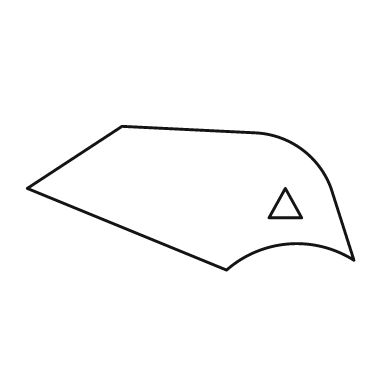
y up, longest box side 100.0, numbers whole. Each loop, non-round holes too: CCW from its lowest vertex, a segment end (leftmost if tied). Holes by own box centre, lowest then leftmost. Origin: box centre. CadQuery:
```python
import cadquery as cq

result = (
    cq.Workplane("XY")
    .moveTo(11.0, -22.0)
    .threePointArc((30.0, -14.0), (50.0, -19.0))
    .lineTo(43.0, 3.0)
    .threePointArc((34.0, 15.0), (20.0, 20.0))
    .lineTo(-21.0, 22.0)
    .lineTo(-50.0, 3.0)
    .close()
    .moveTo(24.0, -6.0)
    .lineTo(34.0, -6.0)
    .lineTo(29.0, 3.0)
    .close()
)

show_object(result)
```